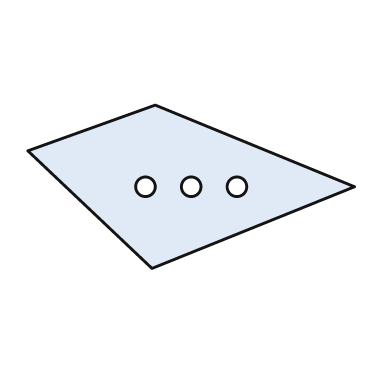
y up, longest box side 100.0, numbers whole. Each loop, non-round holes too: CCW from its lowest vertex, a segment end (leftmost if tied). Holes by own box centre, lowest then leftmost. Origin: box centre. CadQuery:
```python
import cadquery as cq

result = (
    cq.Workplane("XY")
    .moveTo(-12.0, -25.0)
    .lineTo(50.0, 0.0)
    .lineTo(-11.0, 25.0)
    .lineTo(-50.0, 11.0)
    .close()
    .moveTo(-14.0, 0.0)
    .circle(3.0)
    .moveTo(0.0, 0.0)
    .circle(3.0)
    .moveTo(14.0, 0.0)
    .circle(3.0)
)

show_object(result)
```